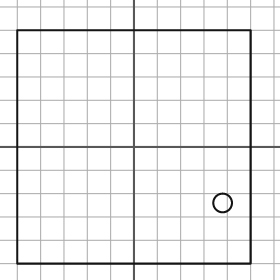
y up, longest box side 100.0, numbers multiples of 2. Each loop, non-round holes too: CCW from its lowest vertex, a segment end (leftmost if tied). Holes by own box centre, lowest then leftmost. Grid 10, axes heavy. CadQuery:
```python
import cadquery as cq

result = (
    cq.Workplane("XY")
    .moveTo(-50.0, -50.0)
    .lineTo(50.0, -50.0)
    .lineTo(50.0, 50.0)
    .lineTo(-50.0, 50.0)
    .close()
    .moveTo(38.0, -24.0)
    .circle(4.0)
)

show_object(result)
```